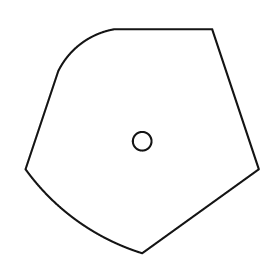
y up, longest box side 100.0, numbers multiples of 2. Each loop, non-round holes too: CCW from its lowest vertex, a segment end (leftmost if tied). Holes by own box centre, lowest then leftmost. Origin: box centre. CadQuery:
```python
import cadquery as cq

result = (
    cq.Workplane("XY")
    .moveTo(0.0, -48.0)
    .lineTo(50.0, -12.0)
    .lineTo(30.0, 48.0)
    .lineTo(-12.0, 48.0)
    .threePointArc((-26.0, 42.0), (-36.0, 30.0))
    .lineTo(-50.0, -12.0)
    .threePointArc((-28.0, -34.0), (0.0, -48.0))
    .close()
    .moveTo(0.0, 0.0)
    .circle(4.0)
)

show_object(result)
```